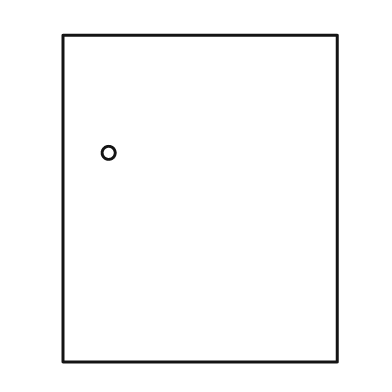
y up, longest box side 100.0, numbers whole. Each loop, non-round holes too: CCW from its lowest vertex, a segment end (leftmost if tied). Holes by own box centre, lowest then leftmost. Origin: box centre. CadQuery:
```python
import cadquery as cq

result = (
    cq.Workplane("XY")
    .moveTo(-42.0, -50.0)
    .lineTo(42.0, -50.0)
    .lineTo(42.0, 50.0)
    .lineTo(-42.0, 50.0)
    .close()
    .moveTo(-28.0, 14.0)
    .circle(2.0)
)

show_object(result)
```